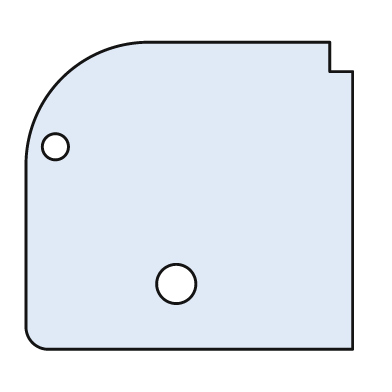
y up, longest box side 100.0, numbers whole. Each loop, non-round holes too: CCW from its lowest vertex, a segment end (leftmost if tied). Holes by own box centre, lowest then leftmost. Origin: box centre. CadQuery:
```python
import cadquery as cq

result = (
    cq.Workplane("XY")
    .moveTo(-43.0, -47.0)
    .lineTo(50.0, -47.0)
    .lineTo(50.0, 38.0)
    .lineTo(43.0, 38.0)
    .lineTo(43.0, 47.0)
    .lineTo(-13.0, 47.0)
    .threePointArc((-39.0, 36.0), (-50.0, 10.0))
    .lineTo(-50.0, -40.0)
    .threePointArc((-48.0, -45.0), (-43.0, -47.0))
    .close()
    .moveTo(-4.0, -27.0)
    .circle(6.0)
    .moveTo(-41.0, 15.0)
    .circle(4.0)
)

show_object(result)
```